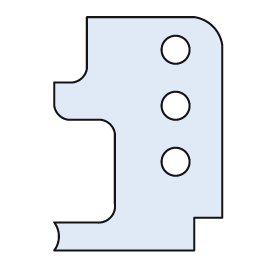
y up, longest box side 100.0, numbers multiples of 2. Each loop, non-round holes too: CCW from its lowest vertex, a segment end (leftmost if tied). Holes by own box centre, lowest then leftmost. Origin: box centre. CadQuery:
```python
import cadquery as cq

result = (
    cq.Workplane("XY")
    .moveTo(-36.0, -50.0)
    .lineTo(24.0, -50.0)
    .lineTo(24.0, -36.0)
    .lineTo(36.0, -36.0)
    .lineTo(36.0, 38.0)
    .threePointArc((32.0, 46.0), (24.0, 50.0))
    .lineTo(-22.0, 50.0)
    .lineTo(-22.0, 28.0)
    .threePointArc((-24.0, 24.0), (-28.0, 22.0))
    .lineTo(-36.0, 22.0)
    .lineTo(-36.0, 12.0)
    .threePointArc((-34.0, 8.0), (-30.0, 6.0))
    .lineTo(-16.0, 6.0)
    .threePointArc((-12.0, 4.0), (-10.0, 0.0))
    .lineTo(-10.0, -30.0)
    .threePointArc((-12.0, -36.0), (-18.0, -38.0))
    .lineTo(-36.0, -38.0)
    .threePointArc((-34.0, -44.0), (-36.0, -50.0))
    .close()
    .moveTo(16.0, -12.0)
    .circle(6.0)
    .moveTo(16.0, 12.0)
    .circle(6.0)
    .moveTo(16.0, 36.0)
    .circle(6.0)
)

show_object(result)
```